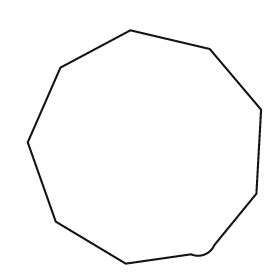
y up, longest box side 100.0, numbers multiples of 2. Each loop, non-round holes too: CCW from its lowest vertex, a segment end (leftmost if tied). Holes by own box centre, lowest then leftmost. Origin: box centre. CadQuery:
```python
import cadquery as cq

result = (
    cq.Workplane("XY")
    .moveTo(-8.0, -50.0)
    .lineTo(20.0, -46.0)
    .threePointArc((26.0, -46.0), (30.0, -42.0))
    .lineTo(48.0, -20.0)
    .lineTo(50.0, 16.0)
    .lineTo(28.0, 42.0)
    .lineTo(-6.0, 50.0)
    .lineTo(-36.0, 34.0)
    .lineTo(-50.0, 2.0)
    .lineTo(-38.0, -32.0)
    .close()
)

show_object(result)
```